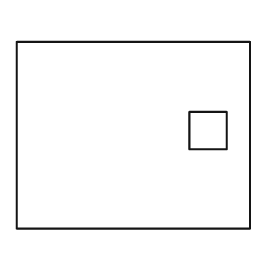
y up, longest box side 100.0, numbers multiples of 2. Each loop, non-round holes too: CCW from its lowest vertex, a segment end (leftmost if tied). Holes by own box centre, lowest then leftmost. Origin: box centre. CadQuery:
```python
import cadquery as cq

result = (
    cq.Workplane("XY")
    .moveTo(-50.0, -40.0)
    .lineTo(50.0, -40.0)
    .lineTo(50.0, 40.0)
    .lineTo(-50.0, 40.0)
    .close()
    .moveTo(24.0, -6.0)
    .lineTo(40.0, -6.0)
    .lineTo(40.0, 10.0)
    .lineTo(24.0, 10.0)
    .close()
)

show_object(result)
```